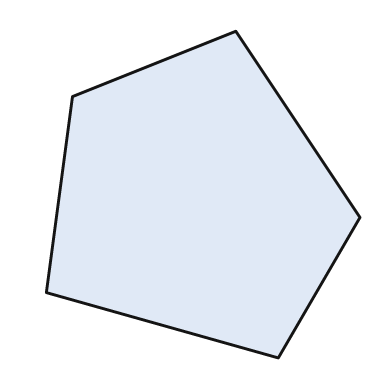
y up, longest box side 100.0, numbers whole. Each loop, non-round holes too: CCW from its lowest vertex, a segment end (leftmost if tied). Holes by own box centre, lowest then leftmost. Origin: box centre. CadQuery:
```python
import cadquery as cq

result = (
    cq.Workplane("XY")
    .moveTo(23.0, -50.0)
    .lineTo(48.0, -7.0)
    .lineTo(10.0, 50.0)
    .lineTo(-40.0, 30.0)
    .lineTo(-48.0, -30.0)
    .close()
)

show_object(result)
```